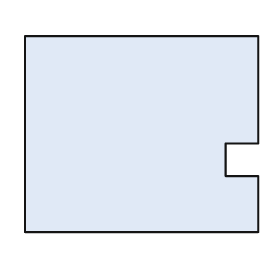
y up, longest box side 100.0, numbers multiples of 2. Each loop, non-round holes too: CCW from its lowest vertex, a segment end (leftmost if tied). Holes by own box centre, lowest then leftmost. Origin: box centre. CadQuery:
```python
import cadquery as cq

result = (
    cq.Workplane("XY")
    .moveTo(-50.0, -42.0)
    .lineTo(50.0, -42.0)
    .lineTo(50.0, -18.0)
    .lineTo(36.0, -18.0)
    .lineTo(36.0, -4.0)
    .lineTo(50.0, -4.0)
    .lineTo(50.0, 42.0)
    .lineTo(-50.0, 42.0)
    .close()
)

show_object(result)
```